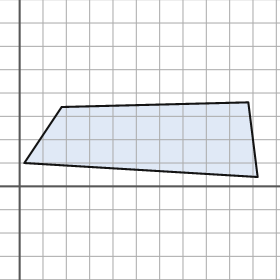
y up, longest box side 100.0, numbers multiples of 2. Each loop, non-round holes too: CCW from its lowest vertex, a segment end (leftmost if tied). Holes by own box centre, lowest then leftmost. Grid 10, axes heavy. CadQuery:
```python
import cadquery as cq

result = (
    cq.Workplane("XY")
    .moveTo(102.0, 4.0)
    .lineTo(98.0, 36.0)
    .lineTo(18.0, 34.0)
    .lineTo(2.0, 10.0)
    .close()
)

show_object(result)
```